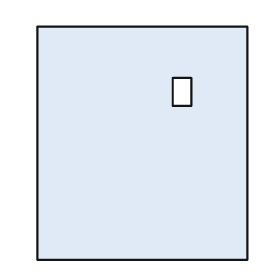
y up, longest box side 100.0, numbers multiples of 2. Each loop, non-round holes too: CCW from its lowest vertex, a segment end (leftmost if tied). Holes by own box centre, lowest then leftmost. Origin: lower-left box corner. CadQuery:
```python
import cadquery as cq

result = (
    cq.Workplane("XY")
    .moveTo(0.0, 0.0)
    .lineTo(90.0, 0.0)
    .lineTo(90.0, 100.0)
    .lineTo(0.0, 100.0)
    .close()
    .moveTo(58.0, 66.0)
    .lineTo(66.0, 66.0)
    .lineTo(66.0, 78.0)
    .lineTo(58.0, 78.0)
    .close()
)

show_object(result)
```